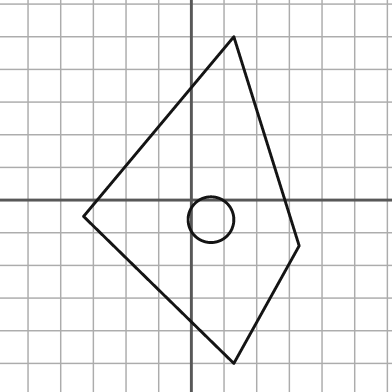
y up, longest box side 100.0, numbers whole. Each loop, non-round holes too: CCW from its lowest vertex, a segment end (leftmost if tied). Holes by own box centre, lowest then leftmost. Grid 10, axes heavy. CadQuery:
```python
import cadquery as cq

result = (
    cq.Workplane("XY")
    .moveTo(13.0, -50.0)
    .lineTo(33.0, -14.0)
    .lineTo(13.0, 50.0)
    .lineTo(-33.0, -5.0)
    .close()
    .moveTo(6.0, -6.0)
    .circle(7.0)
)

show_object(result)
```